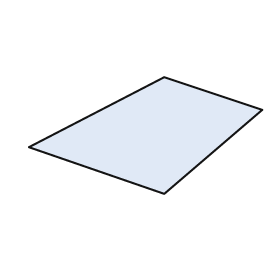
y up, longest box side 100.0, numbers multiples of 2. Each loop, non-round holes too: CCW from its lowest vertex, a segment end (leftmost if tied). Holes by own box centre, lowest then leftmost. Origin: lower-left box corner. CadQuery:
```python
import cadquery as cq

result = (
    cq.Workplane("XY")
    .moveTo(58.0, 0.0)
    .lineTo(100.0, 36.0)
    .lineTo(58.0, 50.0)
    .lineTo(0.0, 20.0)
    .close()
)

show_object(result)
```